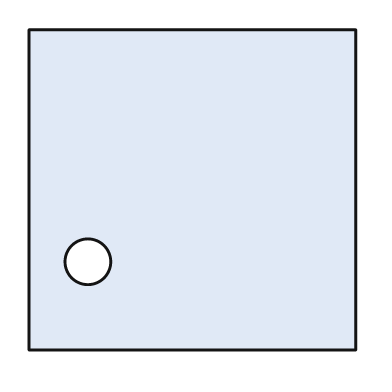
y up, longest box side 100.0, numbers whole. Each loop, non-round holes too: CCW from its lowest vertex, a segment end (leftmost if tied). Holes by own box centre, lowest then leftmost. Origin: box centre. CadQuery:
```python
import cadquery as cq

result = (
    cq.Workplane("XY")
    .moveTo(-50.0, -49.0)
    .lineTo(50.0, -49.0)
    .lineTo(50.0, 49.0)
    .lineTo(-50.0, 49.0)
    .close()
    .moveTo(-32.0, -22.0)
    .circle(7.0)
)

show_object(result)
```